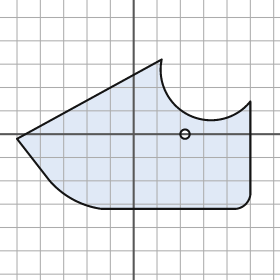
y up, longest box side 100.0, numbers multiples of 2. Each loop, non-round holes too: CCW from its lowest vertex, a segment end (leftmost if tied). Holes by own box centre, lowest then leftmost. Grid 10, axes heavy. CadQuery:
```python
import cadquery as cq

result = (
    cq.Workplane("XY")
    .moveTo(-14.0, -32.0)
    .lineTo(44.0, -32.0)
    .threePointArc((48.0, -30.0), (50.0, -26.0))
    .lineTo(50.0, 14.0)
    .threePointArc((24.0, 8.0), (12.0, 32.0))
    .lineTo(-50.0, -2.0)
    .lineTo(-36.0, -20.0)
    .threePointArc((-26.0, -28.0), (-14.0, -32.0))
    .close()
    .moveTo(22.0, 0.0)
    .circle(2.0)
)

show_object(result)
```